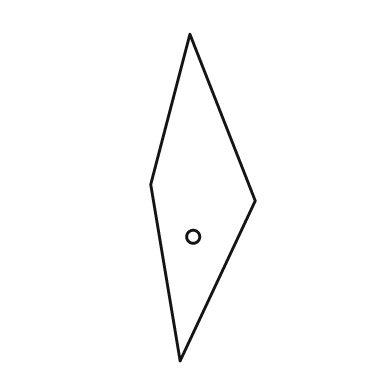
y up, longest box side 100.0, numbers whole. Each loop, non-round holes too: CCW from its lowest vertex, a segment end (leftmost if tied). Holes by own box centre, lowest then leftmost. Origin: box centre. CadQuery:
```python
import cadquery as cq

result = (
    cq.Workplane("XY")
    .moveTo(-7.0, -50.0)
    .lineTo(16.0, -1.0)
    .lineTo(-4.0, 50.0)
    .lineTo(-16.0, 4.0)
    .close()
    .moveTo(-3.0, -12.0)
    .circle(2.0)
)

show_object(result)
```